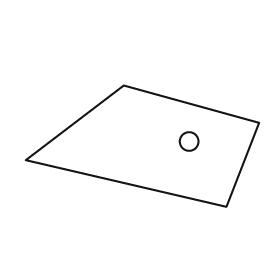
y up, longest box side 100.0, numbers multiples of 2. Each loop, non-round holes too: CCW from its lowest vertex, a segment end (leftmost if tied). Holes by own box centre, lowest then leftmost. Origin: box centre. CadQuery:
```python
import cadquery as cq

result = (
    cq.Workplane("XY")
    .moveTo(36.0, -26.0)
    .lineTo(50.0, 10.0)
    .lineTo(-8.0, 26.0)
    .lineTo(-50.0, -6.0)
    .close()
    .moveTo(20.0, 2.0)
    .circle(4.0)
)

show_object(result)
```